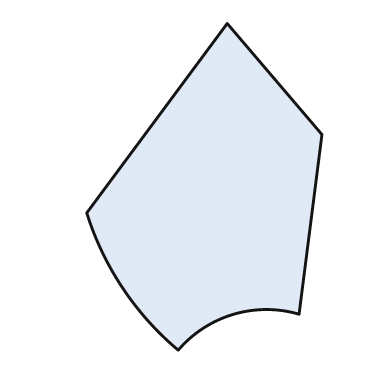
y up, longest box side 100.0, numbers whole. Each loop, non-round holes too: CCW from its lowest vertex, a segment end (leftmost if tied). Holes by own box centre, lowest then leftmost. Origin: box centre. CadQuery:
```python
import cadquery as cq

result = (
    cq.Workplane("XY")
    .moveTo(-8.0, -50.0)
    .threePointArc((9.0, -39.0), (29.0, -39.0))
    .lineTo(36.0, 16.0)
    .lineTo(7.0, 50.0)
    .lineTo(-36.0, -8.0)
    .threePointArc((-25.0, -31.0), (-8.0, -50.0))
    .close()
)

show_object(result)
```